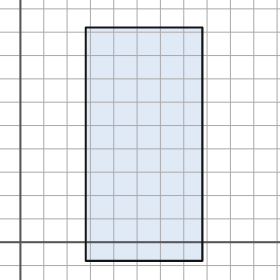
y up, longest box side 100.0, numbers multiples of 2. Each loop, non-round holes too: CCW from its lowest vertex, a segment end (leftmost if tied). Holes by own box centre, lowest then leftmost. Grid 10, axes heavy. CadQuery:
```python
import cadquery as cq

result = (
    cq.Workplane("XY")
    .moveTo(28.0, -8.0)
    .lineTo(78.0, -8.0)
    .lineTo(78.0, 92.0)
    .lineTo(28.0, 92.0)
    .close()
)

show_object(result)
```